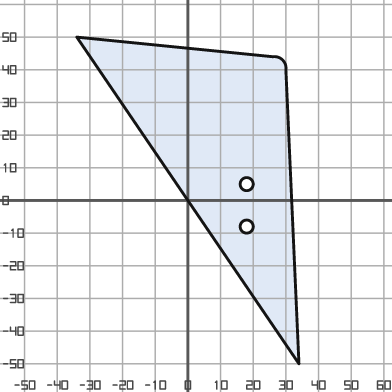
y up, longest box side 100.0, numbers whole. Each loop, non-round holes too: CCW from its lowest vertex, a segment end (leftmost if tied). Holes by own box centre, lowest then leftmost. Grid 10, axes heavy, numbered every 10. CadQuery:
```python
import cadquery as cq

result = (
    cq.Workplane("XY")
    .moveTo(34.0, -50.0)
    .lineTo(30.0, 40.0)
    .threePointArc((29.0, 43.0), (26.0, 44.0))
    .lineTo(-34.0, 50.0)
    .close()
    .moveTo(18.0, -8.0)
    .circle(2.0)
    .moveTo(18.0, 5.0)
    .circle(2.0)
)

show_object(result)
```